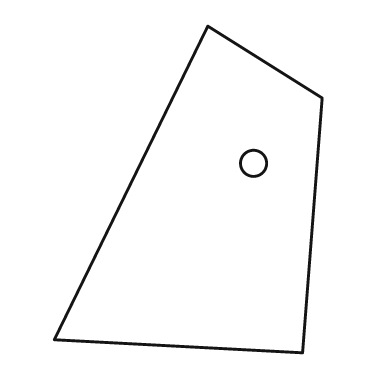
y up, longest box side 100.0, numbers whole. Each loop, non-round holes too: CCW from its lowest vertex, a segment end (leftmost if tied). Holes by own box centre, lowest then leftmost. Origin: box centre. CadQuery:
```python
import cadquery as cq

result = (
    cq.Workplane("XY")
    .moveTo(35.0, -50.0)
    .lineTo(41.0, 28.0)
    .lineTo(6.0, 50.0)
    .lineTo(-41.0, -46.0)
    .close()
    .moveTo(20.0, 8.0)
    .circle(4.0)
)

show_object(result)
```